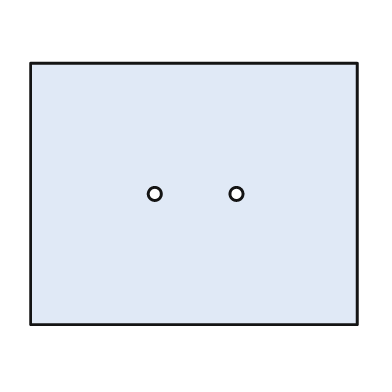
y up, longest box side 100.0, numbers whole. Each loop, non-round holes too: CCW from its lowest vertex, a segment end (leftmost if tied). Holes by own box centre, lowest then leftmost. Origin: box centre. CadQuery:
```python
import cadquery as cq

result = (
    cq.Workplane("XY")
    .moveTo(-50.0, -40.0)
    .lineTo(50.0, -40.0)
    .lineTo(50.0, 40.0)
    .lineTo(-50.0, 40.0)
    .close()
    .moveTo(-12.0, 0.0)
    .circle(2.0)
    .moveTo(13.0, 0.0)
    .circle(2.0)
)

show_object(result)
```